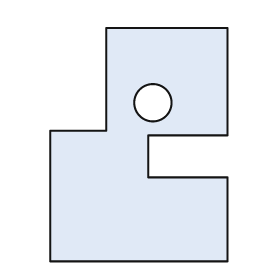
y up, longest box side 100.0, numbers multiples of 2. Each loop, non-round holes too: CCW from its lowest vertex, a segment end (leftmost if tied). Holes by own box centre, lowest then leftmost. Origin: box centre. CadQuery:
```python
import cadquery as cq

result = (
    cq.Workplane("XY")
    .moveTo(-38.0, -50.0)
    .lineTo(38.0, -50.0)
    .lineTo(38.0, -14.0)
    .lineTo(4.0, -14.0)
    .lineTo(4.0, 4.0)
    .lineTo(38.0, 4.0)
    .lineTo(38.0, 50.0)
    .lineTo(-14.0, 50.0)
    .lineTo(-14.0, 6.0)
    .lineTo(-38.0, 6.0)
    .close()
    .moveTo(6.0, 18.0)
    .circle(8.0)
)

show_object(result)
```